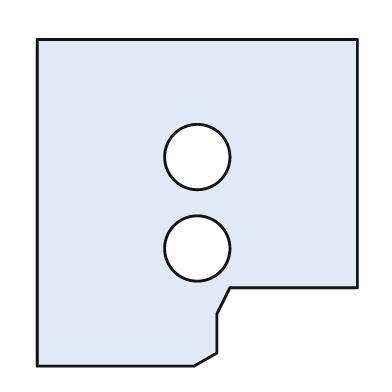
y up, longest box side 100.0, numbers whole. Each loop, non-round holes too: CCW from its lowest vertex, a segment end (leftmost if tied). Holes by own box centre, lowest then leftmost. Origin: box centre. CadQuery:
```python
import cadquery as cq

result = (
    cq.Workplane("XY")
    .moveTo(-49.0, -50.0)
    .lineTo(-1.0, -50.0)
    .lineTo(6.0, -46.0)
    .lineTo(6.0, -34.0)
    .lineTo(10.0, -26.0)
    .lineTo(49.0, -26.0)
    .lineTo(49.0, 50.0)
    .lineTo(-49.0, 50.0)
    .close()
    .moveTo(0.0, -14.0)
    .circle(10.0)
    .moveTo(0.0, 14.0)
    .circle(10.0)
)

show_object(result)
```